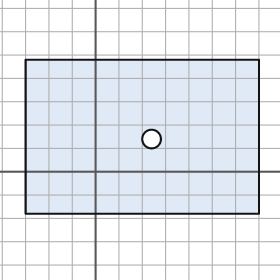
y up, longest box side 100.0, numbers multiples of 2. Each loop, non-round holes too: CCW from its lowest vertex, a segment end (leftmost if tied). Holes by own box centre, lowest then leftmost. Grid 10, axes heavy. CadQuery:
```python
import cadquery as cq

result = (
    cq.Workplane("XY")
    .moveTo(-30.0, -18.0)
    .lineTo(70.0, -18.0)
    .lineTo(70.0, 48.0)
    .lineTo(-30.0, 48.0)
    .close()
    .moveTo(24.0, 14.0)
    .circle(4.0)
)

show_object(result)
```